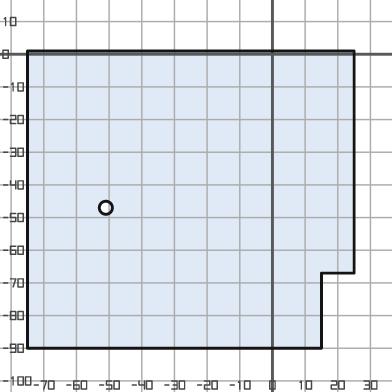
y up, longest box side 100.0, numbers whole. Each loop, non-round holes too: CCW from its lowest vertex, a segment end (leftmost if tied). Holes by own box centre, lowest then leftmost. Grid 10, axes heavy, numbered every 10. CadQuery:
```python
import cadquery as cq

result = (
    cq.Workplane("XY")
    .moveTo(-75.0, -90.0)
    .lineTo(15.0, -90.0)
    .lineTo(15.0, -67.0)
    .lineTo(25.0, -67.0)
    .lineTo(25.0, 1.0)
    .lineTo(-75.0, 1.0)
    .close()
    .moveTo(-51.0, -47.0)
    .circle(2.0)
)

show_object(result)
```